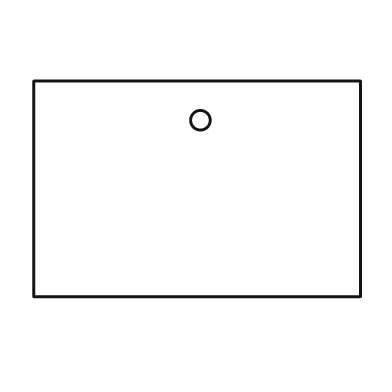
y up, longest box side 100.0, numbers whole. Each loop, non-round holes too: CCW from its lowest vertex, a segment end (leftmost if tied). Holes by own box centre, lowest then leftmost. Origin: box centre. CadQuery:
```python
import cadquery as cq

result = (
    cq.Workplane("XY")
    .moveTo(-50.0, -33.0)
    .lineTo(50.0, -33.0)
    .lineTo(50.0, 33.0)
    .lineTo(-50.0, 33.0)
    .close()
    .moveTo(1.0, 21.0)
    .circle(3.0)
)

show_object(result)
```